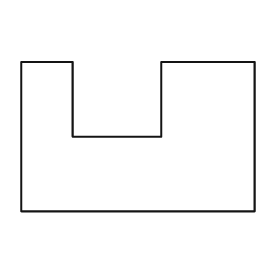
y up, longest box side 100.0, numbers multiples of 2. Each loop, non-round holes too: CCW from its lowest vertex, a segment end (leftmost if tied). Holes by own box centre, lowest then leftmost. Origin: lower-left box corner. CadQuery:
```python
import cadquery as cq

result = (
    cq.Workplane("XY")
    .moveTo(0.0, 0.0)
    .lineTo(100.0, 0.0)
    .lineTo(100.0, 64.0)
    .lineTo(60.0, 64.0)
    .lineTo(60.0, 32.0)
    .lineTo(22.0, 32.0)
    .lineTo(22.0, 64.0)
    .lineTo(0.0, 64.0)
    .close()
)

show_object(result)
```